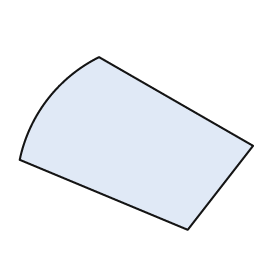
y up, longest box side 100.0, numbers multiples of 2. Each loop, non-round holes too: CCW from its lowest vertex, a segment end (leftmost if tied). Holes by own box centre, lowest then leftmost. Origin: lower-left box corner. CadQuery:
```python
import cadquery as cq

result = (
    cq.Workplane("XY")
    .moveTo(72.0, 0.0)
    .lineTo(100.0, 36.0)
    .lineTo(34.0, 74.0)
    .threePointArc((12.0, 56.0), (0.0, 30.0))
    .close()
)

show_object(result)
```